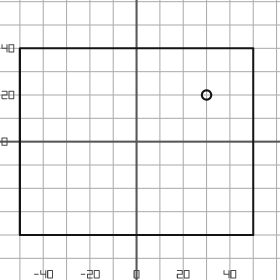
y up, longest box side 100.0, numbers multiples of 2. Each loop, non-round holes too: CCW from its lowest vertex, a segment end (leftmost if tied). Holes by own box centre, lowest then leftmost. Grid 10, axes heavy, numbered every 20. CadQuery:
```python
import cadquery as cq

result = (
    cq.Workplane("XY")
    .moveTo(-50.0, -40.0)
    .lineTo(50.0, -40.0)
    .lineTo(50.0, 40.0)
    .lineTo(-50.0, 40.0)
    .close()
    .moveTo(30.0, 20.0)
    .circle(2.0)
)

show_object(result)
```